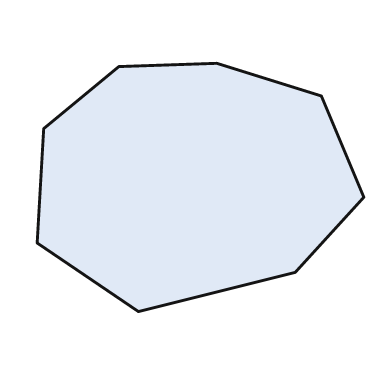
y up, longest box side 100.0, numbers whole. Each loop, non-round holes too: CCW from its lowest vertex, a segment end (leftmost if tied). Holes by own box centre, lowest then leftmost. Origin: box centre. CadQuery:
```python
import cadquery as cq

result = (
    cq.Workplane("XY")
    .moveTo(-19.0, -38.0)
    .lineTo(29.0, -26.0)
    .lineTo(50.0, -3.0)
    .lineTo(37.0, 28.0)
    .lineTo(5.0, 38.0)
    .lineTo(-25.0, 37.0)
    .lineTo(-48.0, 18.0)
    .lineTo(-50.0, -17.0)
    .close()
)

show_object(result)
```